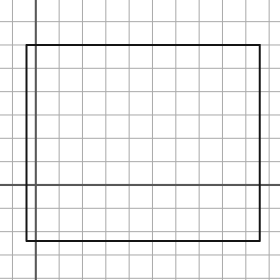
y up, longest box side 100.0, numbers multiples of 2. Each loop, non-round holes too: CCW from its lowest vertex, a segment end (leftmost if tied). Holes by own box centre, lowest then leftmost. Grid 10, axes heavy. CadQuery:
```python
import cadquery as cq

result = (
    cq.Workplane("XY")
    .moveTo(-4.0, -24.0)
    .lineTo(96.0, -24.0)
    .lineTo(96.0, 60.0)
    .lineTo(-4.0, 60.0)
    .close()
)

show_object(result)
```